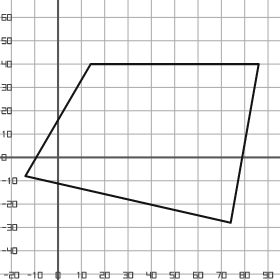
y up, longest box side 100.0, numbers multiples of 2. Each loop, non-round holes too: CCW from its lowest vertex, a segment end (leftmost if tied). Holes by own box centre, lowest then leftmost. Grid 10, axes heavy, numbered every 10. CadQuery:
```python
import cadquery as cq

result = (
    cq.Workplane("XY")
    .moveTo(74.0, -28.0)
    .lineTo(86.0, 40.0)
    .lineTo(14.0, 40.0)
    .lineTo(-14.0, -8.0)
    .close()
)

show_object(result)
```